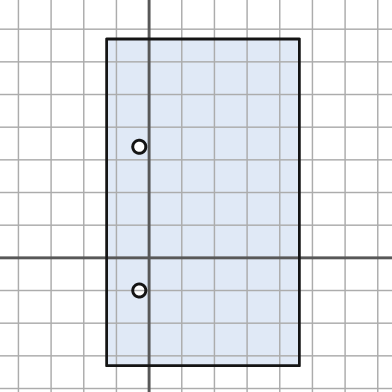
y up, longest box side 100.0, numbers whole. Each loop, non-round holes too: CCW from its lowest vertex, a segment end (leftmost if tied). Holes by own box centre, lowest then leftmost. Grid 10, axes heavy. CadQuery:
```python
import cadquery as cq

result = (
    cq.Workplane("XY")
    .moveTo(-13.0, -33.0)
    .lineTo(46.0, -33.0)
    .lineTo(46.0, 67.0)
    .lineTo(-13.0, 67.0)
    .close()
    .moveTo(-3.0, -10.0)
    .circle(2.0)
    .moveTo(-3.0, 34.0)
    .circle(2.0)
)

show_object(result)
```